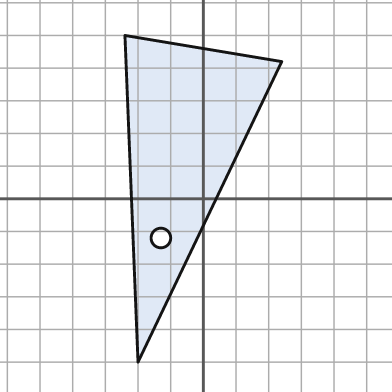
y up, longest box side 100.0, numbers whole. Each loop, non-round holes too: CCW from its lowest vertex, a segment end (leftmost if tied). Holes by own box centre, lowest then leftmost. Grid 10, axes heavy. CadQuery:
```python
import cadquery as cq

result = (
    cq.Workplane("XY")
    .moveTo(-20.0, -50.0)
    .lineTo(24.0, 42.0)
    .lineTo(-24.0, 50.0)
    .close()
    .moveTo(-13.0, -12.0)
    .circle(3.0)
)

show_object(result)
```